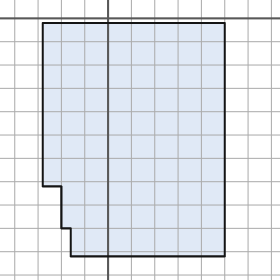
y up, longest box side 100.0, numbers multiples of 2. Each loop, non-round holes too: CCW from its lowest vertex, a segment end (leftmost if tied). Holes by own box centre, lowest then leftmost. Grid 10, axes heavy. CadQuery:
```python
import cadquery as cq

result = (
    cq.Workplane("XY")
    .moveTo(-16.0, -102.0)
    .lineTo(50.0, -102.0)
    .lineTo(50.0, -2.0)
    .lineTo(-28.0, -2.0)
    .lineTo(-28.0, -72.0)
    .lineTo(-20.0, -72.0)
    .lineTo(-20.0, -90.0)
    .lineTo(-16.0, -90.0)
    .close()
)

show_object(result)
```